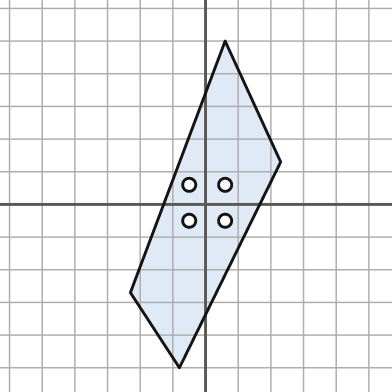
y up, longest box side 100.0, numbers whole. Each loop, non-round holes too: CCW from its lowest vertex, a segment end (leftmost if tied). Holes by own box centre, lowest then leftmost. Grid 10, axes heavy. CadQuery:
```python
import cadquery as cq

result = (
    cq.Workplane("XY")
    .moveTo(-8.0, -50.0)
    .lineTo(23.0, 13.0)
    .lineTo(6.0, 50.0)
    .lineTo(-23.0, -27.0)
    .close()
    .moveTo(-5.0, -5.0)
    .circle(2.0)
    .moveTo(6.0, -5.0)
    .circle(2.0)
    .moveTo(-5.0, 6.0)
    .circle(2.0)
    .moveTo(6.0, 6.0)
    .circle(2.0)
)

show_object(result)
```